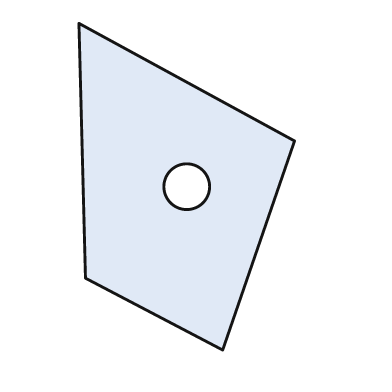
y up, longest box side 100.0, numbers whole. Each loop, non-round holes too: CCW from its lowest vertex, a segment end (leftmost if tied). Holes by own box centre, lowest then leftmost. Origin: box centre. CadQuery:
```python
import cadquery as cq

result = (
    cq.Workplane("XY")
    .moveTo(11.0, -50.0)
    .lineTo(33.0, 14.0)
    .lineTo(-33.0, 50.0)
    .lineTo(-31.0, -28.0)
    .close()
    .moveTo(0.0, 0.0)
    .circle(7.0)
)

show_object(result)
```